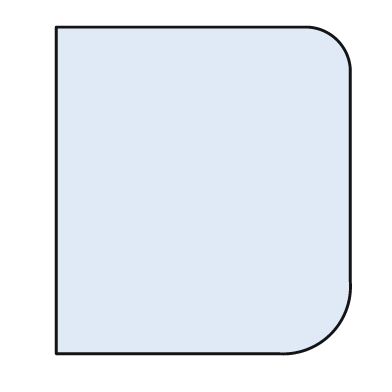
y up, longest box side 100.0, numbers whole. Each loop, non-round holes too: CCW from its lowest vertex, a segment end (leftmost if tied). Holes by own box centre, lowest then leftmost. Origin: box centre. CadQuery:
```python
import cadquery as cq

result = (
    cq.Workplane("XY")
    .moveTo(-45.0, -50.0)
    .lineTo(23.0, -50.0)
    .threePointArc((39.0, -44.0), (45.0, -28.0))
    .lineTo(45.0, 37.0)
    .threePointArc((41.0, 46.0), (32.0, 50.0))
    .lineTo(-45.0, 50.0)
    .close()
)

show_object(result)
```